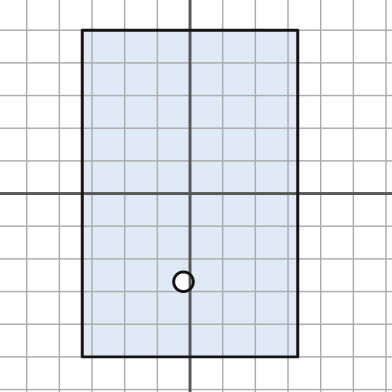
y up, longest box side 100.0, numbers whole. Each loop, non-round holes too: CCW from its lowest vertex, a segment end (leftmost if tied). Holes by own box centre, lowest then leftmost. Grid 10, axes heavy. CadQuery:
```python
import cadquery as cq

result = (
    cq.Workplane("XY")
    .moveTo(-33.0, -50.0)
    .lineTo(33.0, -50.0)
    .lineTo(33.0, 50.0)
    .lineTo(-33.0, 50.0)
    .close()
    .moveTo(-2.0, -27.0)
    .circle(3.0)
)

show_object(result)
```